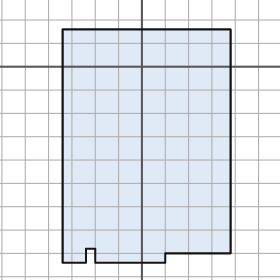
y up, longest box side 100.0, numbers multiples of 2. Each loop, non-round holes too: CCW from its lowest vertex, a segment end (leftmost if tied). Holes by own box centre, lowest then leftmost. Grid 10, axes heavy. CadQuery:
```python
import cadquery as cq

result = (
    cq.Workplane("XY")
    .moveTo(-34.0, -84.0)
    .lineTo(-24.0, -84.0)
    .lineTo(-24.0, -78.0)
    .lineTo(-20.0, -78.0)
    .lineTo(-20.0, -84.0)
    .lineTo(10.0, -84.0)
    .lineTo(10.0, -80.0)
    .lineTo(38.0, -80.0)
    .lineTo(38.0, 16.0)
    .lineTo(-34.0, 16.0)
    .close()
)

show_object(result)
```